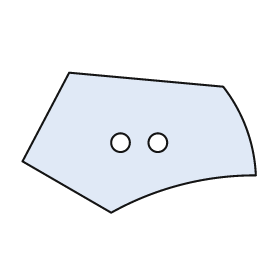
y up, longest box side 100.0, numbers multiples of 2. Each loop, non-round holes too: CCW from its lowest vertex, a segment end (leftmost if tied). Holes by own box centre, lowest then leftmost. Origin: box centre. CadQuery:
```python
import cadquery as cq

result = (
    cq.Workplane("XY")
    .moveTo(-12.0, -30.0)
    .threePointArc((18.0, -18.0), (50.0, -14.0))
    .threePointArc((46.0, 6.0), (36.0, 24.0))
    .lineTo(-30.0, 30.0)
    .lineTo(-50.0, -8.0)
    .close()
    .moveTo(-8.0, 0.0)
    .circle(4.0)
    .moveTo(8.0, 0.0)
    .circle(4.0)
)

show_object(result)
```